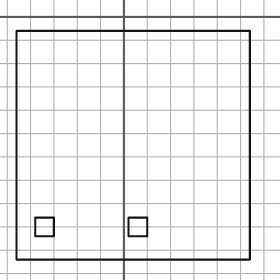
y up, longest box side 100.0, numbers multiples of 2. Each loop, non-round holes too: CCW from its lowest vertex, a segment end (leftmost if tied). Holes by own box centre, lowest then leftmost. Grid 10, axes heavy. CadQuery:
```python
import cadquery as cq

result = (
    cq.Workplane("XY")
    .moveTo(-46.0, -104.0)
    .lineTo(54.0, -104.0)
    .lineTo(54.0, -6.0)
    .lineTo(-46.0, -6.0)
    .close()
    .moveTo(-38.0, -94.0)
    .lineTo(-30.0, -94.0)
    .lineTo(-30.0, -86.0)
    .lineTo(-38.0, -86.0)
    .close()
    .moveTo(2.0, -94.0)
    .lineTo(10.0, -94.0)
    .lineTo(10.0, -86.0)
    .lineTo(2.0, -86.0)
    .close()
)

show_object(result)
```